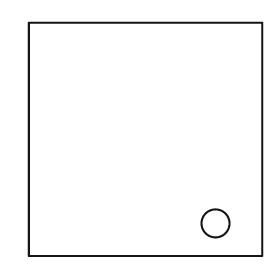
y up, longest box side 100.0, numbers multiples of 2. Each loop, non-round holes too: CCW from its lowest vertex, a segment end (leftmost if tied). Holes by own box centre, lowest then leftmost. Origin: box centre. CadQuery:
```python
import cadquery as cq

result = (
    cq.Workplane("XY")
    .moveTo(-50.0, -50.0)
    .lineTo(50.0, -50.0)
    .lineTo(50.0, 50.0)
    .lineTo(-50.0, 50.0)
    .close()
    .moveTo(30.0, -36.0)
    .circle(6.0)
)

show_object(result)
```